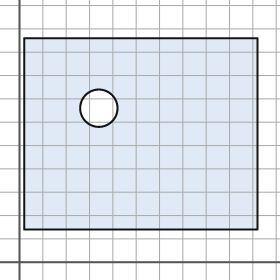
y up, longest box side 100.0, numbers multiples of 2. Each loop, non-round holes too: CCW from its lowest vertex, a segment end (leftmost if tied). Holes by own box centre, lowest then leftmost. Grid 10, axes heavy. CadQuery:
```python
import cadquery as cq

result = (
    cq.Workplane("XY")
    .moveTo(2.0, 14.0)
    .lineTo(102.0, 14.0)
    .lineTo(102.0, 96.0)
    .lineTo(2.0, 96.0)
    .close()
    .moveTo(34.0, 66.0)
    .circle(8.0)
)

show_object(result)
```